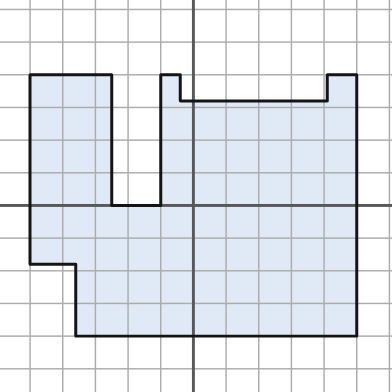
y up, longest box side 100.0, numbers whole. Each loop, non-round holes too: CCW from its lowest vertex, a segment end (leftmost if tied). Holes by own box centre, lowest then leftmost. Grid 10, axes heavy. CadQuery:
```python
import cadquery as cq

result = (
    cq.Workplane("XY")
    .moveTo(-36.0, -40.0)
    .lineTo(50.0, -40.0)
    .lineTo(50.0, 40.0)
    .lineTo(41.0, 40.0)
    .lineTo(41.0, 32.0)
    .lineTo(-4.0, 32.0)
    .lineTo(-4.0, 40.0)
    .lineTo(-10.0, 40.0)
    .lineTo(-10.0, 0.0)
    .lineTo(-25.0, 0.0)
    .lineTo(-25.0, 40.0)
    .lineTo(-50.0, 40.0)
    .lineTo(-50.0, -18.0)
    .lineTo(-36.0, -18.0)
    .close()
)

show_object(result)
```